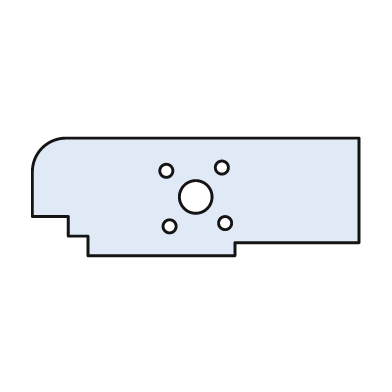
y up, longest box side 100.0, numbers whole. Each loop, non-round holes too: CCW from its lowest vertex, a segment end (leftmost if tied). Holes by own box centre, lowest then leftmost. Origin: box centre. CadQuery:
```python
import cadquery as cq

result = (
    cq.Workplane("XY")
    .moveTo(-33.0, -18.0)
    .lineTo(12.0, -18.0)
    .lineTo(12.0, -14.0)
    .lineTo(50.0, -14.0)
    .lineTo(50.0, 18.0)
    .lineTo(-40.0, 18.0)
    .threePointArc((-47.0, 15.0), (-50.0, 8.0))
    .lineTo(-50.0, -6.0)
    .lineTo(-39.0, -6.0)
    .lineTo(-39.0, -12.0)
    .lineTo(-33.0, -12.0)
    .close()
    .moveTo(-8.0, -9.0)
    .circle(2.0)
    .moveTo(9.0, -8.0)
    .circle(2.0)
    .moveTo(0.0, 0.0)
    .circle(5.0)
    .moveTo(-9.0, 8.0)
    .circle(2.0)
    .moveTo(8.0, 9.0)
    .circle(2.0)
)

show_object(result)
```